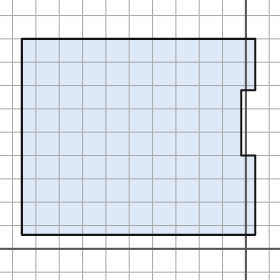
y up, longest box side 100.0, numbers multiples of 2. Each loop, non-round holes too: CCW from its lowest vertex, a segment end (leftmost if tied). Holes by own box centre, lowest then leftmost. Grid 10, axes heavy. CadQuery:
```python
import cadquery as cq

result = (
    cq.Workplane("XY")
    .moveTo(-96.0, 6.0)
    .lineTo(4.0, 6.0)
    .lineTo(4.0, 40.0)
    .lineTo(-2.0, 40.0)
    .lineTo(-2.0, 68.0)
    .lineTo(4.0, 68.0)
    .lineTo(4.0, 90.0)
    .lineTo(-96.0, 90.0)
    .close()
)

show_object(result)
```